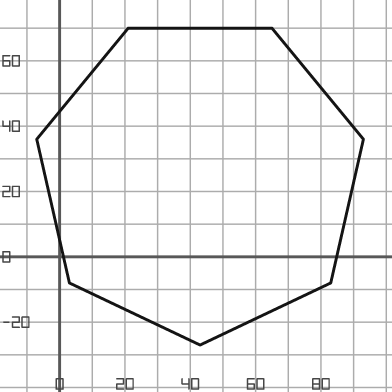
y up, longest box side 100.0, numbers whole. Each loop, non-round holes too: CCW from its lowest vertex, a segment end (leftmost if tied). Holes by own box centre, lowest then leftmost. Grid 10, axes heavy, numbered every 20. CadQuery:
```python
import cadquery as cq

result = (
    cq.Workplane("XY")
    .moveTo(43.0, -27.0)
    .lineTo(83.0, -8.0)
    .lineTo(93.0, 36.0)
    .lineTo(65.0, 70.0)
    .lineTo(21.0, 70.0)
    .lineTo(-7.0, 36.0)
    .lineTo(3.0, -8.0)
    .close()
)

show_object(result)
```